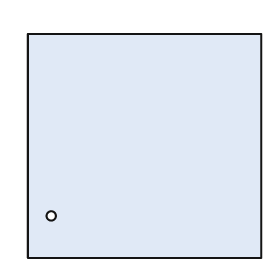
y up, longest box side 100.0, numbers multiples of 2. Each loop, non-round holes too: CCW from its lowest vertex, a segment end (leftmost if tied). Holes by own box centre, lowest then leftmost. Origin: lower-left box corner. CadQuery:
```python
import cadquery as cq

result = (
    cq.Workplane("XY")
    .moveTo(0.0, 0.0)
    .lineTo(100.0, 0.0)
    .lineTo(100.0, 96.0)
    .lineTo(0.0, 96.0)
    .close()
    .moveTo(10.0, 18.0)
    .circle(2.0)
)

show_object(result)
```